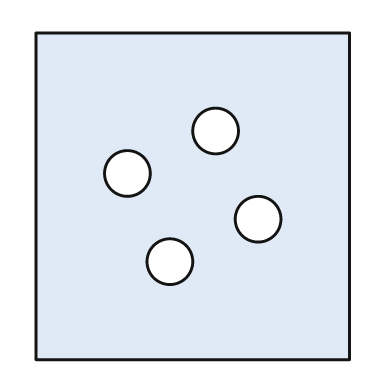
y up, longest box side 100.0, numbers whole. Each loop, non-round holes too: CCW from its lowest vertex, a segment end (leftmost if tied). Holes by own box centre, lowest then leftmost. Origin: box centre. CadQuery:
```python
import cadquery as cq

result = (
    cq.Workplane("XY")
    .moveTo(-48.0, -50.0)
    .lineTo(48.0, -50.0)
    .lineTo(48.0, 50.0)
    .lineTo(-48.0, 50.0)
    .close()
    .moveTo(-7.0, -20.0)
    .circle(7.0)
    .moveTo(20.0, -7.0)
    .circle(7.0)
    .moveTo(-20.0, 7.0)
    .circle(7.0)
    .moveTo(7.0, 20.0)
    .circle(7.0)
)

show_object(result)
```